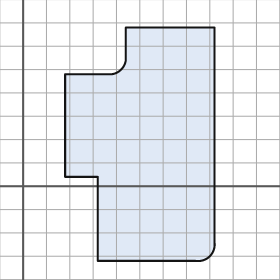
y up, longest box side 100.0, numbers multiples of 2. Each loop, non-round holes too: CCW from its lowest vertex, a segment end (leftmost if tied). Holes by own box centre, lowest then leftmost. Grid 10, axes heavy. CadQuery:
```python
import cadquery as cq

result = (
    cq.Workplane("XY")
    .moveTo(32.0, -32.0)
    .lineTo(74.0, -32.0)
    .threePointArc((80.0, -30.0), (82.0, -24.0))
    .lineTo(82.0, 68.0)
    .lineTo(44.0, 68.0)
    .lineTo(44.0, 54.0)
    .threePointArc((42.0, 50.0), (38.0, 48.0))
    .lineTo(18.0, 48.0)
    .lineTo(18.0, 4.0)
    .lineTo(32.0, 4.0)
    .close()
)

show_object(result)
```